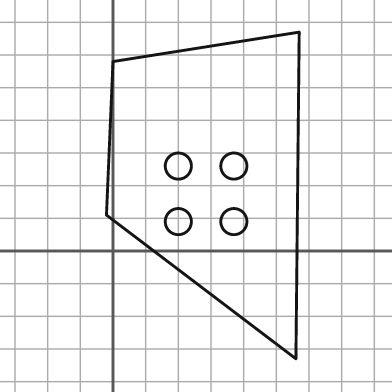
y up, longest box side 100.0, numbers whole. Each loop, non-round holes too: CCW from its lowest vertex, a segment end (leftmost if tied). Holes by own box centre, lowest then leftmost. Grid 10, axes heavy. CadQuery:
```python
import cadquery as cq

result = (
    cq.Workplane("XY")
    .moveTo(56.0, -33.0)
    .lineTo(57.0, 67.0)
    .lineTo(0.0, 58.0)
    .lineTo(-2.0, 11.0)
    .close()
    .moveTo(20.0, 9.0)
    .circle(4.0)
    .moveTo(37.0, 9.0)
    .circle(4.0)
    .moveTo(20.0, 26.0)
    .circle(4.0)
    .moveTo(37.0, 26.0)
    .circle(4.0)
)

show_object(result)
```